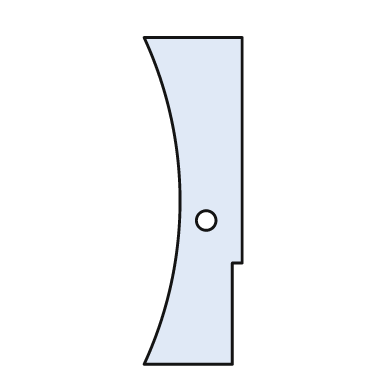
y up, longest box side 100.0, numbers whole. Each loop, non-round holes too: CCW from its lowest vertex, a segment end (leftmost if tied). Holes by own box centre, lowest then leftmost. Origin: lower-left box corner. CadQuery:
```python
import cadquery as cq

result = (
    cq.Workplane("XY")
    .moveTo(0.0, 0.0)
    .lineTo(27.0, 0.0)
    .lineTo(27.0, 31.0)
    .lineTo(30.0, 31.0)
    .lineTo(30.0, 100.0)
    .lineTo(0.0, 100.0)
    .threePointArc((11.0, 50.0), (0.0, 0.0))
    .close()
    .moveTo(19.0, 44.0)
    .circle(3.0)
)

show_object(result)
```